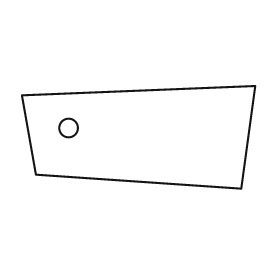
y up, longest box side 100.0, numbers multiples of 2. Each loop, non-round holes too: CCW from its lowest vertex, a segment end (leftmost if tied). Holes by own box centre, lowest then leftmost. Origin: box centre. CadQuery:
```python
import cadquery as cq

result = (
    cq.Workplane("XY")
    .moveTo(44.0, -22.0)
    .lineTo(50.0, 22.0)
    .lineTo(-50.0, 18.0)
    .lineTo(-44.0, -16.0)
    .close()
    .moveTo(-30.0, 4.0)
    .circle(4.0)
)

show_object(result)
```